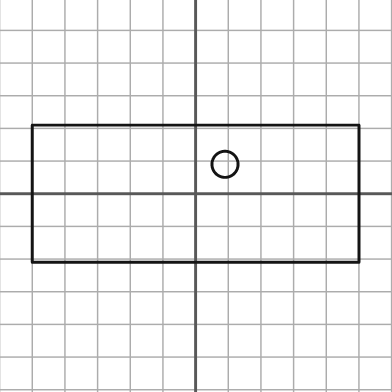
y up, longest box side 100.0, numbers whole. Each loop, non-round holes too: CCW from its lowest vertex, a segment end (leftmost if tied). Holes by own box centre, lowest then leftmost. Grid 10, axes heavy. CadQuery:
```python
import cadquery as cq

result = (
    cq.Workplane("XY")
    .moveTo(-50.0, -21.0)
    .lineTo(50.0, -21.0)
    .lineTo(50.0, 21.0)
    .lineTo(-50.0, 21.0)
    .close()
    .moveTo(9.0, 9.0)
    .circle(4.0)
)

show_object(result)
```